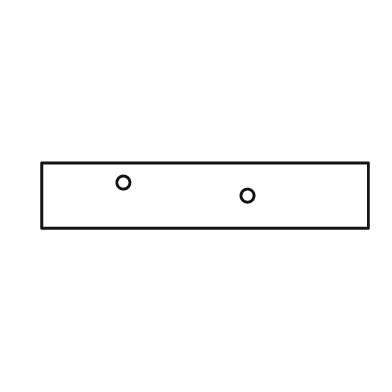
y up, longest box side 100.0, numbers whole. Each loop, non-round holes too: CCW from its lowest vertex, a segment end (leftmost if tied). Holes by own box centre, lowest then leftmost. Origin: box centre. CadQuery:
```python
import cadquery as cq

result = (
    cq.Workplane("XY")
    .moveTo(-50.0, -10.0)
    .lineTo(50.0, -10.0)
    .lineTo(50.0, 10.0)
    .lineTo(-50.0, 10.0)
    .close()
    .moveTo(13.0, 0.0)
    .circle(2.0)
    .moveTo(-25.0, 4.0)
    .circle(2.0)
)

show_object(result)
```